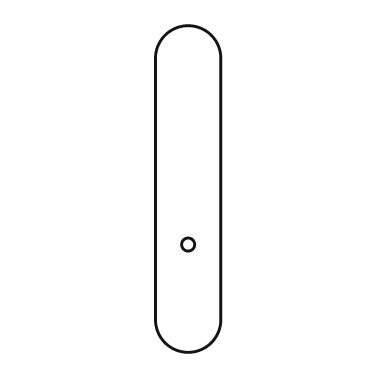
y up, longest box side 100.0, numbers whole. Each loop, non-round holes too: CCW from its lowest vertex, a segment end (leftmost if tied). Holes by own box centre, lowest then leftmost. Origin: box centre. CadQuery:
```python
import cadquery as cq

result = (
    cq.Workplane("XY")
    .moveTo(-10.0, -40.0)
    .threePointArc((0.0, -50.0), (10.0, -40.0))
    .lineTo(10.0, 40.0)
    .threePointArc((0.0, 50.0), (-10.0, 40.0))
    .close()
    .moveTo(0.0, -17.0)
    .circle(2.0)
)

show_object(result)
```